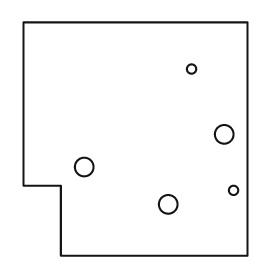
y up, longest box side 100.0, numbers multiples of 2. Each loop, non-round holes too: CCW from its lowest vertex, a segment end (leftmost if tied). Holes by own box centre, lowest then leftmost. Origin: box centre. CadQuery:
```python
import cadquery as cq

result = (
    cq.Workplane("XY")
    .moveTo(-32.0, -50.0)
    .lineTo(48.0, -50.0)
    .lineTo(48.0, 50.0)
    .lineTo(-48.0, 50.0)
    .lineTo(-48.0, -20.0)
    .lineTo(-32.0, -20.0)
    .close()
    .moveTo(14.0, -28.0)
    .circle(4.0)
    .moveTo(42.0, -22.0)
    .circle(2.0)
    .moveTo(-22.0, -12.0)
    .circle(4.0)
    .moveTo(38.0, 2.0)
    .circle(4.0)
    .moveTo(24.0, 30.0)
    .circle(2.0)
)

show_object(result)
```